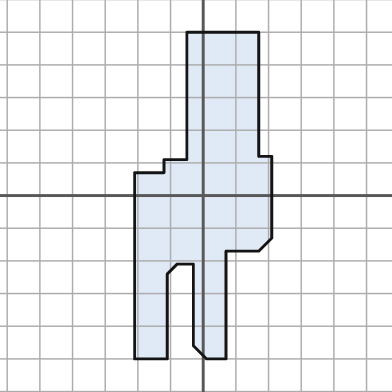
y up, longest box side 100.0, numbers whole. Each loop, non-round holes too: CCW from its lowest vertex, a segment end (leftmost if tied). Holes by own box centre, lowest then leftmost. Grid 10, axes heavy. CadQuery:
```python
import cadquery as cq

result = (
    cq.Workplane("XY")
    .moveTo(-21.0, -50.0)
    .lineTo(-11.0, -50.0)
    .lineTo(-11.0, -24.0)
    .lineTo(-8.0, -21.0)
    .lineTo(-3.0, -21.0)
    .lineTo(-3.0, -46.0)
    .lineTo(1.0, -50.0)
    .lineTo(7.0, -50.0)
    .lineTo(7.0, -17.0)
    .lineTo(17.0, -17.0)
    .lineTo(21.0, -13.0)
    .lineTo(21.0, 12.0)
    .lineTo(17.0, 12.0)
    .lineTo(17.0, 50.0)
    .lineTo(-5.0, 50.0)
    .lineTo(-5.0, 11.0)
    .lineTo(-12.0, 11.0)
    .lineTo(-12.0, 7.0)
    .lineTo(-21.0, 7.0)
    .close()
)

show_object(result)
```